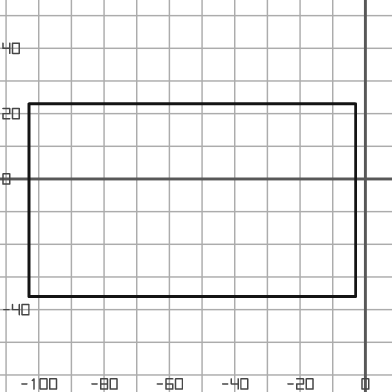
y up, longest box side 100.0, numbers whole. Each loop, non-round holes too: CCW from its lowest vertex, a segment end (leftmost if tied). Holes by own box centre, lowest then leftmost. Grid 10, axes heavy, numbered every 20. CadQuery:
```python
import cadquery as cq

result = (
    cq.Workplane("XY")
    .moveTo(-103.0, -36.0)
    .lineTo(-3.0, -36.0)
    .lineTo(-3.0, 23.0)
    .lineTo(-103.0, 23.0)
    .close()
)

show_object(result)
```